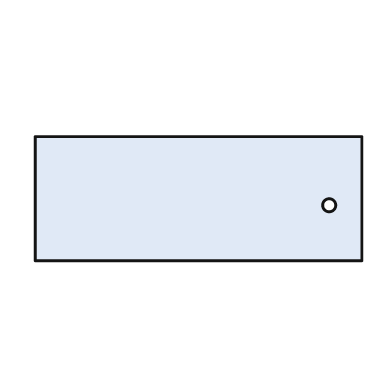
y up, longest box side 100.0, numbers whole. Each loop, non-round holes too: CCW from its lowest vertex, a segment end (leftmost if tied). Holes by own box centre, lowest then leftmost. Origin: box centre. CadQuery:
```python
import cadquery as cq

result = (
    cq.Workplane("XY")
    .moveTo(-50.0, -19.0)
    .lineTo(50.0, -19.0)
    .lineTo(50.0, 19.0)
    .lineTo(-50.0, 19.0)
    .close()
    .moveTo(40.0, -2.0)
    .circle(2.0)
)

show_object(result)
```